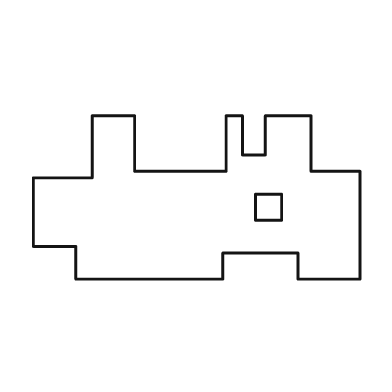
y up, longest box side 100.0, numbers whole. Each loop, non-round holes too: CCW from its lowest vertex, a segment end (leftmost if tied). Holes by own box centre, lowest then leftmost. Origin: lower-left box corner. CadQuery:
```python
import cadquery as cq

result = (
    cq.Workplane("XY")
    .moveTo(13.0, 0.0)
    .lineTo(58.0, 0.0)
    .lineTo(58.0, 8.0)
    .lineTo(81.0, 8.0)
    .lineTo(81.0, 0.0)
    .lineTo(100.0, 0.0)
    .lineTo(100.0, 33.0)
    .lineTo(85.0, 33.0)
    .lineTo(85.0, 50.0)
    .lineTo(71.0, 50.0)
    .lineTo(71.0, 38.0)
    .lineTo(64.0, 38.0)
    .lineTo(64.0, 50.0)
    .lineTo(59.0, 50.0)
    .lineTo(59.0, 33.0)
    .lineTo(31.0, 33.0)
    .lineTo(31.0, 50.0)
    .lineTo(18.0, 50.0)
    .lineTo(18.0, 31.0)
    .lineTo(0.0, 31.0)
    .lineTo(0.0, 10.0)
    .lineTo(13.0, 10.0)
    .close()
    .moveTo(68.0, 18.0)
    .lineTo(76.0, 18.0)
    .lineTo(76.0, 26.0)
    .lineTo(68.0, 26.0)
    .close()
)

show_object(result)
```